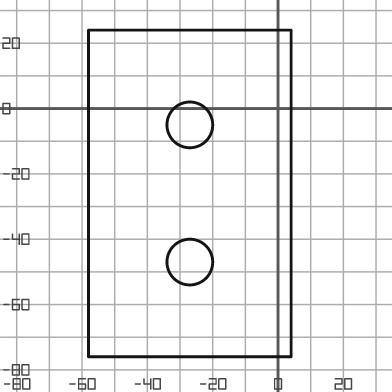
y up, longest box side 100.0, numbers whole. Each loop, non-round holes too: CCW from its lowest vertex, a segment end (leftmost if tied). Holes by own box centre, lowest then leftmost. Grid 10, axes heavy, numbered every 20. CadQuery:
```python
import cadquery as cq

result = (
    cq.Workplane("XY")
    .moveTo(-58.0, -76.0)
    .lineTo(4.0, -76.0)
    .lineTo(4.0, 24.0)
    .lineTo(-58.0, 24.0)
    .close()
    .moveTo(-27.0, -47.0)
    .circle(7.0)
    .moveTo(-27.0, -5.0)
    .circle(7.0)
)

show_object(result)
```